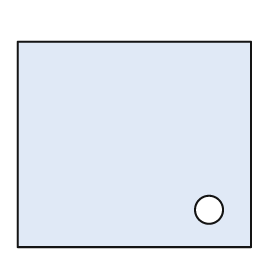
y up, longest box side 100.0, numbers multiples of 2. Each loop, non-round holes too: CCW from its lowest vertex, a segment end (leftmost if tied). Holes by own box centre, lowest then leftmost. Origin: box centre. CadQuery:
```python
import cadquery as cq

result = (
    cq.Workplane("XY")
    .moveTo(-50.0, -44.0)
    .lineTo(50.0, -44.0)
    .lineTo(50.0, 44.0)
    .lineTo(-50.0, 44.0)
    .close()
    .moveTo(32.0, -28.0)
    .circle(6.0)
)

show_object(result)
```